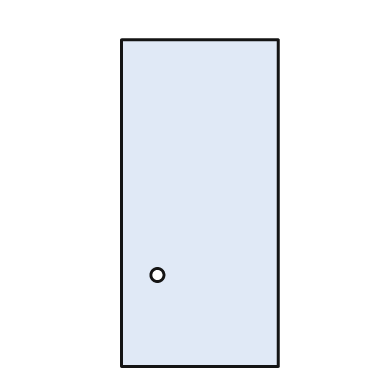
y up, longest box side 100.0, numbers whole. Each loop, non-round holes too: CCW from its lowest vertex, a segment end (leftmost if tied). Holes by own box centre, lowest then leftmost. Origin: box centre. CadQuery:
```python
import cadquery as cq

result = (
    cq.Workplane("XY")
    .moveTo(-24.0, -50.0)
    .lineTo(24.0, -50.0)
    .lineTo(24.0, 50.0)
    .lineTo(-24.0, 50.0)
    .close()
    .moveTo(-13.0, -22.0)
    .circle(2.0)
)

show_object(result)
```